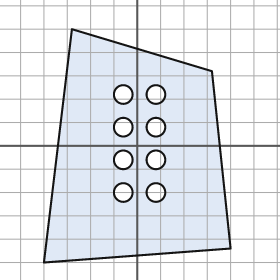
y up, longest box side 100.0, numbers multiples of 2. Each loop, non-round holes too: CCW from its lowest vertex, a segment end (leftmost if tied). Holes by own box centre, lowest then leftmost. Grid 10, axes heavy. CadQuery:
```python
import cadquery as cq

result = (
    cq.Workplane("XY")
    .moveTo(-40.0, -50.0)
    .lineTo(40.0, -44.0)
    .lineTo(32.0, 32.0)
    .lineTo(-28.0, 50.0)
    .close()
    .moveTo(-6.0, -20.0)
    .circle(4.0)
    .moveTo(8.0, -20.0)
    .circle(4.0)
    .moveTo(-6.0, -6.0)
    .circle(4.0)
    .moveTo(8.0, -6.0)
    .circle(4.0)
    .moveTo(-6.0, 8.0)
    .circle(4.0)
    .moveTo(8.0, 8.0)
    .circle(4.0)
    .moveTo(-6.0, 22.0)
    .circle(4.0)
    .moveTo(8.0, 22.0)
    .circle(4.0)
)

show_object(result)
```